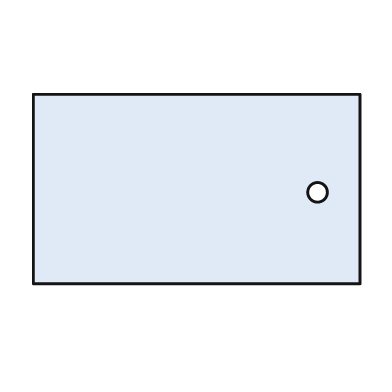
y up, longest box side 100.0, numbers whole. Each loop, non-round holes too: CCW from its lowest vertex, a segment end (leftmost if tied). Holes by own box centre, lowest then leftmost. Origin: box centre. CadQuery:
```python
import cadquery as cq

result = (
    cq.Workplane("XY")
    .moveTo(-50.0, -29.0)
    .lineTo(50.0, -29.0)
    .lineTo(50.0, 29.0)
    .lineTo(-50.0, 29.0)
    .close()
    .moveTo(37.0, -1.0)
    .circle(3.0)
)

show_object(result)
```